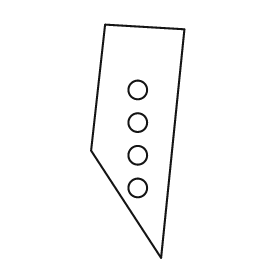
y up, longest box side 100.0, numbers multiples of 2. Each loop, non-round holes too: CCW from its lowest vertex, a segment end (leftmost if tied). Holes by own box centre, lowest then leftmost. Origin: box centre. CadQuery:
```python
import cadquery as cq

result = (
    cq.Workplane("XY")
    .moveTo(10.0, -50.0)
    .lineTo(20.0, 48.0)
    .lineTo(-14.0, 50.0)
    .lineTo(-20.0, -4.0)
    .close()
    .moveTo(0.0, -20.0)
    .circle(4.0)
    .moveTo(0.0, -6.0)
    .circle(4.0)
    .moveTo(0.0, 8.0)
    .circle(4.0)
    .moveTo(0.0, 22.0)
    .circle(4.0)
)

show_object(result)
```